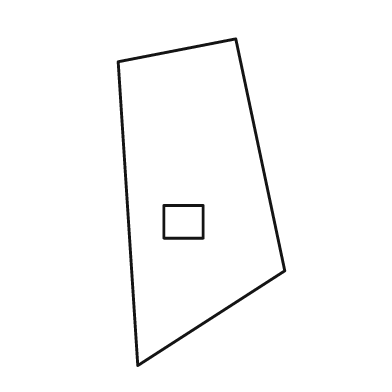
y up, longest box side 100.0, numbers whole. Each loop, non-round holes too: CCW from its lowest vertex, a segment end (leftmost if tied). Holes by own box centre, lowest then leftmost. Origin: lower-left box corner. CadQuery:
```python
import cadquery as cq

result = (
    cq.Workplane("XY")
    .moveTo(6.0, 0.0)
    .lineTo(51.0, 29.0)
    .lineTo(36.0, 100.0)
    .lineTo(0.0, 93.0)
    .close()
    .moveTo(14.0, 39.0)
    .lineTo(26.0, 39.0)
    .lineTo(26.0, 49.0)
    .lineTo(14.0, 49.0)
    .close()
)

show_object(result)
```